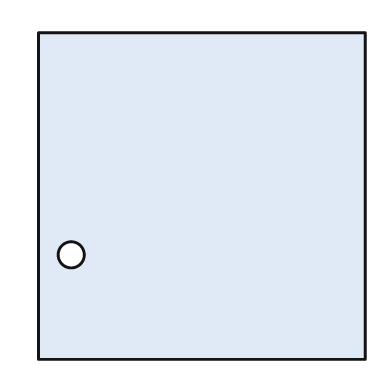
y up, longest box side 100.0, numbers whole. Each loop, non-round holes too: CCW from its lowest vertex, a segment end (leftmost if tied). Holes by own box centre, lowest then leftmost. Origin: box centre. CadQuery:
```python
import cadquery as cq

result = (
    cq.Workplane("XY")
    .moveTo(-50.0, -50.0)
    .lineTo(50.0, -50.0)
    .lineTo(50.0, 50.0)
    .lineTo(-50.0, 50.0)
    .close()
    .moveTo(-40.0, -18.0)
    .circle(4.0)
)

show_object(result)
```